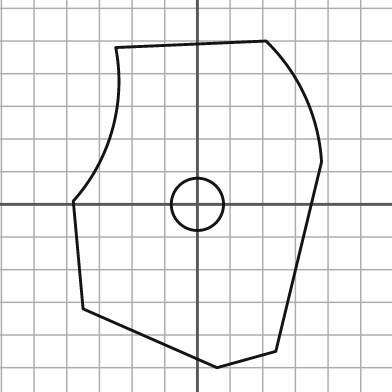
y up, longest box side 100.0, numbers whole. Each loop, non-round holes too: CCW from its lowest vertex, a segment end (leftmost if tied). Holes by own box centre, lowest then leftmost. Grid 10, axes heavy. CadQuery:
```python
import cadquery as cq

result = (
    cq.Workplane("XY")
    .moveTo(6.0, -50.0)
    .lineTo(24.0, -45.0)
    .lineTo(38.0, 13.0)
    .threePointArc((33.0, 33.0), (21.0, 50.0))
    .lineTo(-25.0, 48.0)
    .threePointArc((-26.0, 23.0), (-38.0, 1.0))
    .lineTo(-35.0, -32.0)
    .close()
    .moveTo(0.0, 0.0)
    .circle(8.0)
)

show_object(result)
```